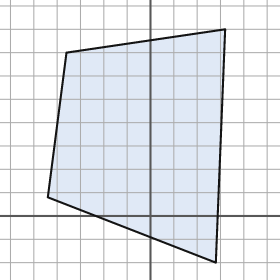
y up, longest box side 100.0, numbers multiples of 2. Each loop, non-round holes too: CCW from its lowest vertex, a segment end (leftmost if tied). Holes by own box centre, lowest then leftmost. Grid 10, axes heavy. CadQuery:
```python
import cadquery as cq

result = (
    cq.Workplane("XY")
    .moveTo(28.0, -20.0)
    .lineTo(32.0, 80.0)
    .lineTo(-36.0, 70.0)
    .lineTo(-44.0, 8.0)
    .close()
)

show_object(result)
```